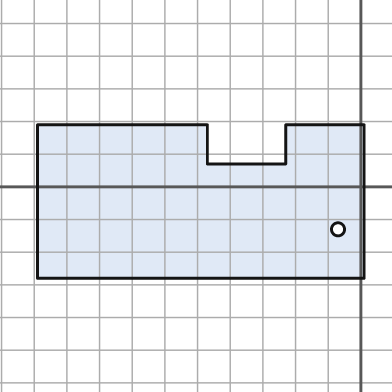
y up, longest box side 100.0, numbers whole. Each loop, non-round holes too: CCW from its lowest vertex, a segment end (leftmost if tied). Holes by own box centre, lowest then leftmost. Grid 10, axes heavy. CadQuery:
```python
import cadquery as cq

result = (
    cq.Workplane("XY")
    .moveTo(-99.0, -28.0)
    .lineTo(1.0, -28.0)
    .lineTo(1.0, 19.0)
    .lineTo(-23.0, 19.0)
    .lineTo(-23.0, 7.0)
    .lineTo(-47.0, 7.0)
    .lineTo(-47.0, 19.0)
    .lineTo(-99.0, 19.0)
    .close()
    .moveTo(-7.0, -13.0)
    .circle(2.0)
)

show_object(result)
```